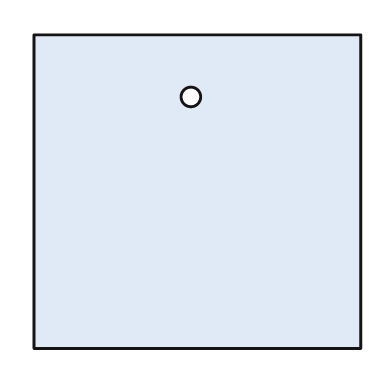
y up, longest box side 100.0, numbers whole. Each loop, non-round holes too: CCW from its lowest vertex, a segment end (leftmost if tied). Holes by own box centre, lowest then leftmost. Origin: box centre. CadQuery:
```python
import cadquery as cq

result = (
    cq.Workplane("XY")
    .moveTo(-50.0, -48.0)
    .lineTo(50.0, -48.0)
    .lineTo(50.0, 48.0)
    .lineTo(-50.0, 48.0)
    .close()
    .moveTo(-2.0, 29.0)
    .circle(3.0)
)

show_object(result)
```